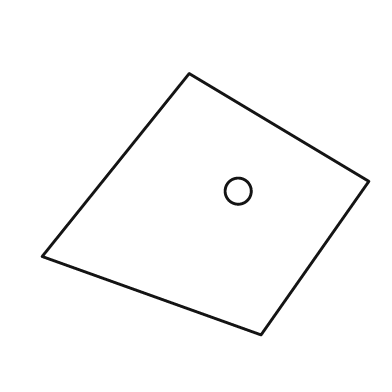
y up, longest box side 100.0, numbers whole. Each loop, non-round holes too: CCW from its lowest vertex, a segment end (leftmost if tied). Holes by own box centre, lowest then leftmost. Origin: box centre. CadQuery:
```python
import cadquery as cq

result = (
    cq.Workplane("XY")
    .moveTo(17.0, -40.0)
    .lineTo(50.0, 7.0)
    .lineTo(-5.0, 40.0)
    .lineTo(-50.0, -16.0)
    .close()
    .moveTo(10.0, 4.0)
    .circle(4.0)
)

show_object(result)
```